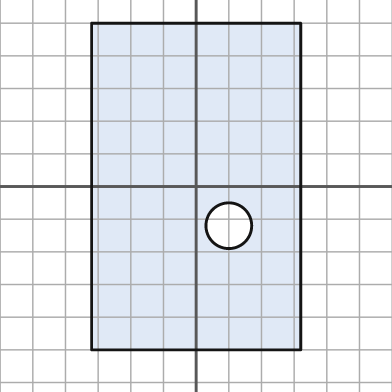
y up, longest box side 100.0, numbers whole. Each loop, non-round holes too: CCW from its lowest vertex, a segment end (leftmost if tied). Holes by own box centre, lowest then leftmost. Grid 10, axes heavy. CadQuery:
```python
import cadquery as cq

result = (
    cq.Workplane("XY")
    .moveTo(-32.0, -50.0)
    .lineTo(32.0, -50.0)
    .lineTo(32.0, 50.0)
    .lineTo(-32.0, 50.0)
    .close()
    .moveTo(10.0, -12.0)
    .circle(7.0)
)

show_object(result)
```